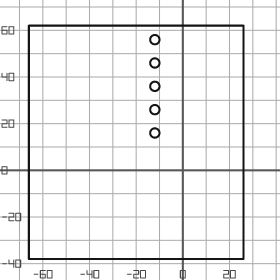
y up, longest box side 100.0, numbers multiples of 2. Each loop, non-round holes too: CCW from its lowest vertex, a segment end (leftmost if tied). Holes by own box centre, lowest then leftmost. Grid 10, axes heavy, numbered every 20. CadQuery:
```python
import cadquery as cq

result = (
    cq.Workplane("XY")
    .moveTo(-66.0, -38.0)
    .lineTo(26.0, -38.0)
    .lineTo(26.0, 62.0)
    .lineTo(-66.0, 62.0)
    .close()
    .moveTo(-12.0, 16.0)
    .circle(2.0)
    .moveTo(-12.0, 26.0)
    .circle(2.0)
    .moveTo(-12.0, 36.0)
    .circle(2.0)
    .moveTo(-12.0, 46.0)
    .circle(2.0)
    .moveTo(-12.0, 56.0)
    .circle(2.0)
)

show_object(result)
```